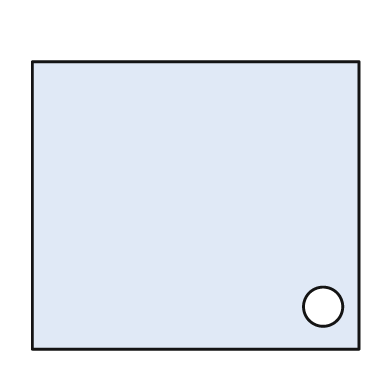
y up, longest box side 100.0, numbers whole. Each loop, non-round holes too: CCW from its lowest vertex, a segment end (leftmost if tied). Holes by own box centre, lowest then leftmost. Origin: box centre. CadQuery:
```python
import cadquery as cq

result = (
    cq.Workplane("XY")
    .moveTo(-50.0, -44.0)
    .lineTo(50.0, -44.0)
    .lineTo(50.0, 44.0)
    .lineTo(-50.0, 44.0)
    .close()
    .moveTo(39.0, -31.0)
    .circle(6.0)
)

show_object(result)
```